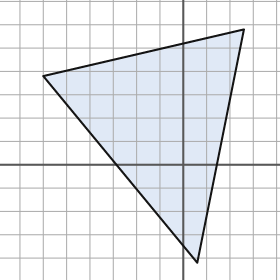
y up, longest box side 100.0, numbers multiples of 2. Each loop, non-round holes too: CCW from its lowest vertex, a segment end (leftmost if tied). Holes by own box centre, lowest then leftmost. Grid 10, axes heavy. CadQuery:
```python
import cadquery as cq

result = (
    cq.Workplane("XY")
    .moveTo(6.0, -42.0)
    .lineTo(26.0, 58.0)
    .lineTo(-60.0, 38.0)
    .close()
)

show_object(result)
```